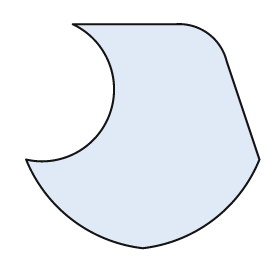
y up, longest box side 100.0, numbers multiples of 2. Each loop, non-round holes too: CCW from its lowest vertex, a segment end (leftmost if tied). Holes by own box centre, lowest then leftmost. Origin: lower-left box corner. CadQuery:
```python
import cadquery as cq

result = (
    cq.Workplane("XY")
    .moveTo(50.0, 0.0)
    .threePointArc((80.0, 12.0), (100.0, 38.0))
    .lineTo(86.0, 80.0)
    .threePointArc((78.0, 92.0), (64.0, 96.0))
    .lineTo(20.0, 96.0)
    .threePointArc((36.0, 58.0), (0.0, 38.0))
    .threePointArc((20.0, 12.0), (50.0, 0.0))
    .close()
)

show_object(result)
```